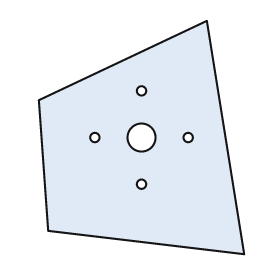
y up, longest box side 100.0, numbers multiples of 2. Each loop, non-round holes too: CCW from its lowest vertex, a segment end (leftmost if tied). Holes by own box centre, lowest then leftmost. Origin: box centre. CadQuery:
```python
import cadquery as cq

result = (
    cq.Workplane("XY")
    .moveTo(44.0, -50.0)
    .lineTo(28.0, 50.0)
    .lineTo(-44.0, 16.0)
    .lineTo(-40.0, -40.0)
    .close()
    .moveTo(0.0, -20.0)
    .circle(2.0)
    .moveTo(-20.0, 0.0)
    .circle(2.0)
    .moveTo(0.0, 0.0)
    .circle(6.0)
    .moveTo(20.0, 0.0)
    .circle(2.0)
    .moveTo(0.0, 20.0)
    .circle(2.0)
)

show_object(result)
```